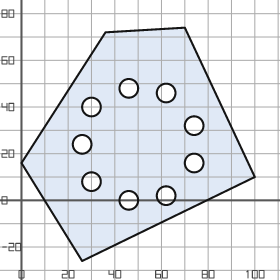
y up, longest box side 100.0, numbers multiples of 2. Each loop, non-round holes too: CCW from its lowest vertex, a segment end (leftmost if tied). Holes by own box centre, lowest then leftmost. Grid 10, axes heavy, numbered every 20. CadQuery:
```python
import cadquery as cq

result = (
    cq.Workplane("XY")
    .moveTo(26.0, -26.0)
    .lineTo(100.0, 10.0)
    .lineTo(70.0, 74.0)
    .lineTo(36.0, 72.0)
    .lineTo(0.0, 16.0)
    .close()
    .moveTo(46.0, 0.0)
    .circle(4.0)
    .moveTo(62.0, 2.0)
    .circle(4.0)
    .moveTo(30.0, 8.0)
    .circle(4.0)
    .moveTo(74.0, 16.0)
    .circle(4.0)
    .moveTo(26.0, 24.0)
    .circle(4.0)
    .moveTo(74.0, 32.0)
    .circle(4.0)
    .moveTo(30.0, 40.0)
    .circle(4.0)
    .moveTo(62.0, 46.0)
    .circle(4.0)
    .moveTo(46.0, 48.0)
    .circle(4.0)
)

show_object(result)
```